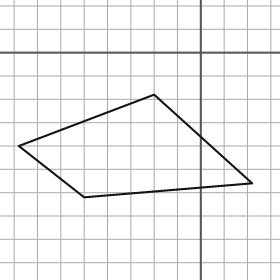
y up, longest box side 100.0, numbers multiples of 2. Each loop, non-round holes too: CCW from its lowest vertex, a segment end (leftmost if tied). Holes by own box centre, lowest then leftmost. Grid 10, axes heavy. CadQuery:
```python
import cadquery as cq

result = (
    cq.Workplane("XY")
    .moveTo(-50.0, -62.0)
    .lineTo(22.0, -56.0)
    .lineTo(-20.0, -18.0)
    .lineTo(-78.0, -40.0)
    .close()
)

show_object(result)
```